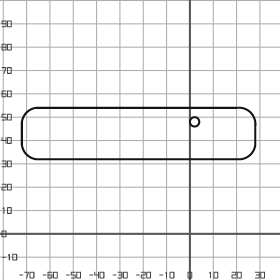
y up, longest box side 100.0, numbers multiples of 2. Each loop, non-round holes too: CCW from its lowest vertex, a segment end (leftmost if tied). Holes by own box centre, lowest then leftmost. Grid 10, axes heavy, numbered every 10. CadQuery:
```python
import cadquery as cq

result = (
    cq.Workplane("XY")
    .moveTo(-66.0, 32.0)
    .lineTo(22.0, 32.0)
    .threePointArc((26.0, 34.0), (28.0, 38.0))
    .lineTo(28.0, 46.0)
    .threePointArc((26.0, 52.0), (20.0, 54.0))
    .lineTo(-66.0, 54.0)
    .threePointArc((-70.0, 52.0), (-72.0, 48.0))
    .lineTo(-72.0, 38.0)
    .threePointArc((-70.0, 34.0), (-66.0, 32.0))
    .close()
    .moveTo(2.0, 48.0)
    .circle(2.0)
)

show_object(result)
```